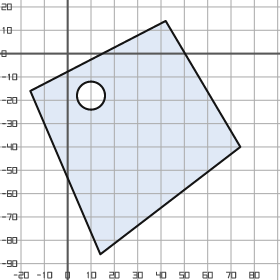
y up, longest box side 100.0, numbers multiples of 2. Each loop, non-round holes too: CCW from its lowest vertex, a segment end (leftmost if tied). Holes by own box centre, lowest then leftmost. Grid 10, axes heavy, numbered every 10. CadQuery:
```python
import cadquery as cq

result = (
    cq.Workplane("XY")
    .moveTo(14.0, -86.0)
    .lineTo(74.0, -40.0)
    .lineTo(42.0, 14.0)
    .lineTo(-16.0, -16.0)
    .close()
    .moveTo(10.0, -18.0)
    .circle(6.0)
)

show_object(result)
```